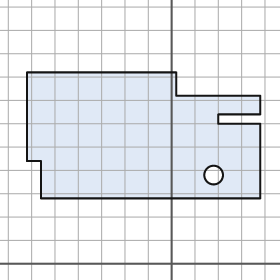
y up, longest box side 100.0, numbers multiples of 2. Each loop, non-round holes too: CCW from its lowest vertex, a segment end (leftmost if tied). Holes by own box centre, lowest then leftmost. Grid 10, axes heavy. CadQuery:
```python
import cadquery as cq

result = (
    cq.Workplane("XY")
    .moveTo(-56.0, 28.0)
    .lineTo(38.0, 28.0)
    .lineTo(38.0, 60.0)
    .lineTo(20.0, 60.0)
    .lineTo(20.0, 64.0)
    .lineTo(38.0, 64.0)
    .lineTo(38.0, 72.0)
    .lineTo(2.0, 72.0)
    .lineTo(2.0, 82.0)
    .lineTo(-62.0, 82.0)
    .lineTo(-62.0, 44.0)
    .lineTo(-56.0, 44.0)
    .close()
    .moveTo(18.0, 38.0)
    .circle(4.0)
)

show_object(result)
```